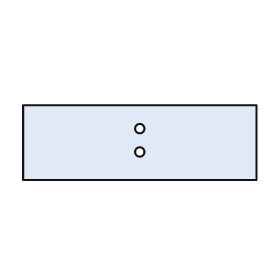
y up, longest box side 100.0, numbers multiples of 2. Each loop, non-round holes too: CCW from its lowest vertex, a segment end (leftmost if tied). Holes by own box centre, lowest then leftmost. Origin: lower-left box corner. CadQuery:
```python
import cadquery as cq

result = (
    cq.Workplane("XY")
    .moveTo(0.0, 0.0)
    .lineTo(100.0, 0.0)
    .lineTo(100.0, 32.0)
    .lineTo(0.0, 32.0)
    .close()
    .moveTo(50.0, 12.0)
    .circle(2.0)
    .moveTo(50.0, 22.0)
    .circle(2.0)
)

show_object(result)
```